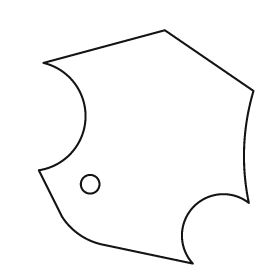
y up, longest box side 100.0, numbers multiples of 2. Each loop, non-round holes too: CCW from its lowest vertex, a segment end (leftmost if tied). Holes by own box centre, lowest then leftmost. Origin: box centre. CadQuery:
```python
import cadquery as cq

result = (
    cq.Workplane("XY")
    .moveTo(20.0, -50.0)
    .threePointArc((20.0, -26.0), (44.0, -24.0))
    .threePointArc((42.0, 0.0), (46.0, 24.0))
    .lineTo(8.0, 50.0)
    .lineTo(-44.0, 36.0)
    .threePointArc((-26.0, 12.0), (-46.0, -10.0))
    .lineTo(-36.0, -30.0)
    .threePointArc((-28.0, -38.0), (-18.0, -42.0))
    .close()
    .moveTo(-24.0, -16.0)
    .circle(4.0)
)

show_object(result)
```